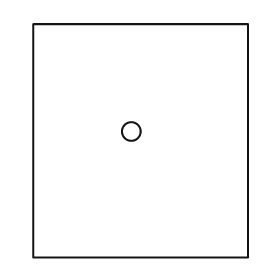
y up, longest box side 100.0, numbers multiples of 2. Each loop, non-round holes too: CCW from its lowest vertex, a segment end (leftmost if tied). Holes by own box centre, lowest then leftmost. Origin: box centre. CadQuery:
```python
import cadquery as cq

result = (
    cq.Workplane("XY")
    .moveTo(-46.0, -50.0)
    .lineTo(46.0, -50.0)
    .lineTo(46.0, 50.0)
    .lineTo(-46.0, 50.0)
    .close()
    .moveTo(-4.0, 4.0)
    .circle(4.0)
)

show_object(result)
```